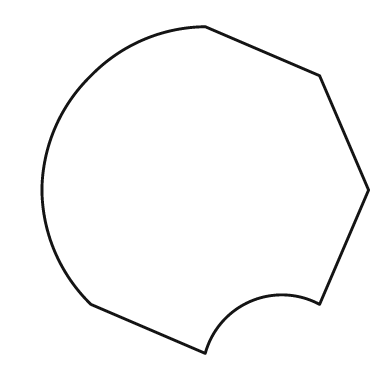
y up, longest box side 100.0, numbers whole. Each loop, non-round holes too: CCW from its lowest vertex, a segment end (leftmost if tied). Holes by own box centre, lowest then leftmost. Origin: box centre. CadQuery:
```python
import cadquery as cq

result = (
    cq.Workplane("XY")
    .moveTo(0.0, -50.0)
    .threePointArc((14.0, -34.0), (35.0, -35.0))
    .lineTo(50.0, 0.0)
    .lineTo(35.0, 35.0)
    .lineTo(0.0, 50.0)
    .threePointArc((-19.0, 46.0), (-35.0, 35.0))
    .threePointArc((-46.0, 19.0), (-50.0, 0.0))
    .threePointArc((-46.0, -19.0), (-35.0, -35.0))
    .close()
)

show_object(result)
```